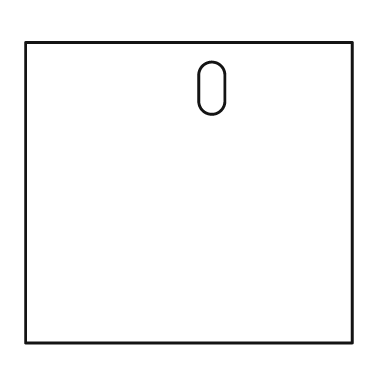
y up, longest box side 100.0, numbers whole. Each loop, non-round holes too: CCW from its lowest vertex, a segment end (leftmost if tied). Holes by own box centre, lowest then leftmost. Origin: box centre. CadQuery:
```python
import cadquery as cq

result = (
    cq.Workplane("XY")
    .moveTo(-50.0, -46.0)
    .lineTo(50.0, -46.0)
    .lineTo(50.0, 46.0)
    .lineTo(-50.0, 46.0)
    .close()
    .moveTo(3.0, 28.0)
    .threePointArc((7.0, 24.0), (11.0, 28.0))
    .lineTo(11.0, 36.0)
    .threePointArc((7.0, 40.0), (3.0, 36.0))
    .close()
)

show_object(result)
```